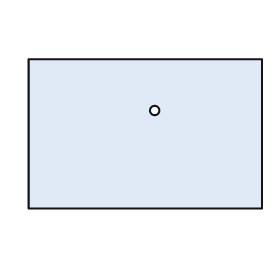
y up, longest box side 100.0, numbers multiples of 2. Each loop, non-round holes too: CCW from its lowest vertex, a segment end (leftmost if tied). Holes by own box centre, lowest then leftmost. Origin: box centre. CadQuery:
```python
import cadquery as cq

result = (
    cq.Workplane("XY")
    .moveTo(-50.0, -32.0)
    .lineTo(50.0, -32.0)
    .lineTo(50.0, 32.0)
    .lineTo(-50.0, 32.0)
    .close()
    .moveTo(4.0, 10.0)
    .circle(2.0)
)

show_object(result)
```